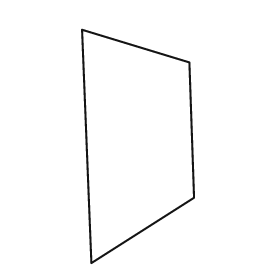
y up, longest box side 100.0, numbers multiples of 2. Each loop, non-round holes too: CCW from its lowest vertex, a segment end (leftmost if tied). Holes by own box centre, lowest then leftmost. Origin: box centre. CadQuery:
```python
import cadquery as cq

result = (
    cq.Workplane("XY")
    .moveTo(-20.0, -50.0)
    .lineTo(24.0, -22.0)
    .lineTo(22.0, 36.0)
    .lineTo(-24.0, 50.0)
    .close()
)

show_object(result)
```